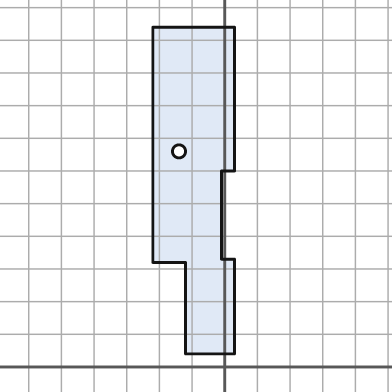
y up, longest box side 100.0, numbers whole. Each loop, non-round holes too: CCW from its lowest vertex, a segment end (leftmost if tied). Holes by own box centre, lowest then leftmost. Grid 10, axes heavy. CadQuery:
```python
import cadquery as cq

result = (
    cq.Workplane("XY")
    .moveTo(-12.0, 4.0)
    .lineTo(3.0, 4.0)
    .lineTo(3.0, 33.0)
    .lineTo(-1.0, 33.0)
    .lineTo(-1.0, 60.0)
    .lineTo(3.0, 60.0)
    .lineTo(3.0, 104.0)
    .lineTo(-22.0, 104.0)
    .lineTo(-22.0, 32.0)
    .lineTo(-12.0, 32.0)
    .close()
    .moveTo(-14.0, 66.0)
    .circle(2.0)
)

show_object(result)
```